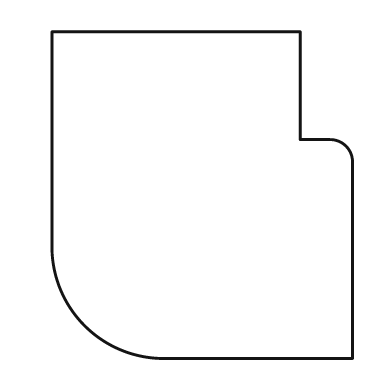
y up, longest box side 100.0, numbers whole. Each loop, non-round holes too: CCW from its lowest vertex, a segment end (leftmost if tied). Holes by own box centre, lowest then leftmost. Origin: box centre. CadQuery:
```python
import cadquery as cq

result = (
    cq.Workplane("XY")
    .moveTo(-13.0, -50.0)
    .lineTo(46.0, -50.0)
    .lineTo(46.0, 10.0)
    .threePointArc((44.0, 15.0), (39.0, 17.0))
    .lineTo(30.0, 17.0)
    .lineTo(30.0, 50.0)
    .lineTo(-46.0, 50.0)
    .lineTo(-46.0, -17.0)
    .threePointArc((-36.0, -40.0), (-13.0, -50.0))
    .close()
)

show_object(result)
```